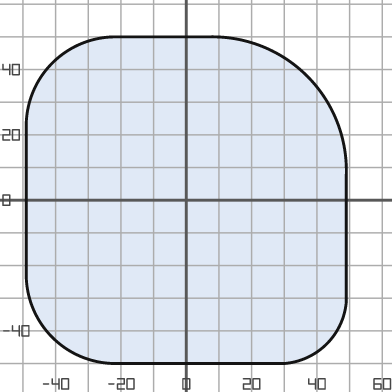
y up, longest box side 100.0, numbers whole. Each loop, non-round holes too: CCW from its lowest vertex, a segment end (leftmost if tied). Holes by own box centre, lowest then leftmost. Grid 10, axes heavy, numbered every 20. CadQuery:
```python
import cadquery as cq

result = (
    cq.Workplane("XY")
    .moveTo(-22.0, -50.0)
    .lineTo(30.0, -50.0)
    .threePointArc((43.0, -44.0), (49.0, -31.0))
    .lineTo(49.0, 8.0)
    .threePointArc((37.0, 38.0), (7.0, 50.0))
    .lineTo(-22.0, 50.0)
    .threePointArc((-41.0, 42.0), (-49.0, 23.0))
    .lineTo(-49.0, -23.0)
    .threePointArc((-41.0, -42.0), (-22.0, -50.0))
    .close()
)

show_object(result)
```